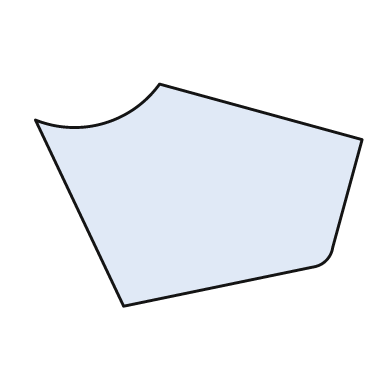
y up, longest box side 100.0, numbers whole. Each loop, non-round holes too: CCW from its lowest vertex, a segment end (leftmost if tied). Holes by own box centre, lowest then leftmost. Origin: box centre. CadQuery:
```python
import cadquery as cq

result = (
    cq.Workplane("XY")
    .moveTo(-23.0, -34.0)
    .lineTo(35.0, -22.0)
    .threePointArc((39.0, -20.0), (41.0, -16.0))
    .lineTo(50.0, 17.0)
    .lineTo(-12.0, 34.0)
    .threePointArc((-29.0, 22.0), (-50.0, 23.0))
    .close()
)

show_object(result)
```